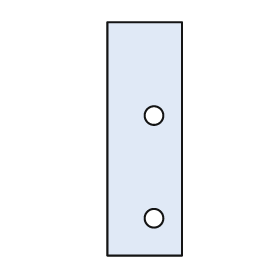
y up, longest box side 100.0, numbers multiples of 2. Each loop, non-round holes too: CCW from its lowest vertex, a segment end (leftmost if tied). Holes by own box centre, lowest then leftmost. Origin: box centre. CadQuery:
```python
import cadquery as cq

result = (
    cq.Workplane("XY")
    .moveTo(-16.0, -50.0)
    .lineTo(16.0, -50.0)
    .lineTo(16.0, 50.0)
    .lineTo(-16.0, 50.0)
    .close()
    .moveTo(4.0, -34.0)
    .circle(4.0)
    .moveTo(4.0, 10.0)
    .circle(4.0)
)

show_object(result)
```